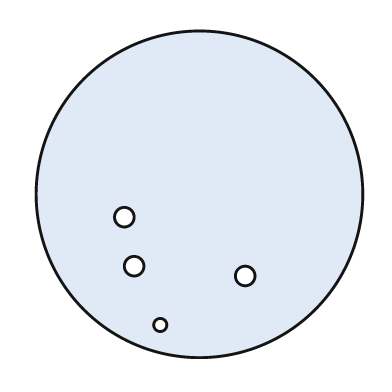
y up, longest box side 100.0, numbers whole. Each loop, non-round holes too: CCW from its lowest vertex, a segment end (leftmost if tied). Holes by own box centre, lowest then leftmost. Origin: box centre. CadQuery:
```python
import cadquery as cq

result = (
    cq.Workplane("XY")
    .moveTo(0.0, 0.0)
    .circle(50.0)
    .moveTo(-12.0, -40.0)
    .circle(2.0)
    .moveTo(14.0, -25.0)
    .circle(3.0)
    .moveTo(-20.0, -22.0)
    .circle(3.0)
    .moveTo(-23.0, -7.0)
    .circle(3.0)
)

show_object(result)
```